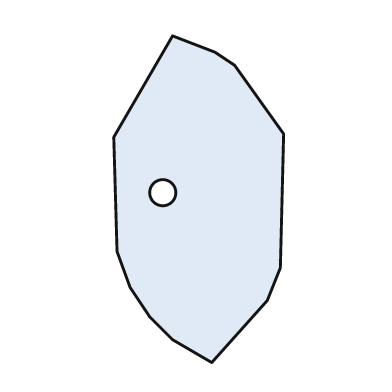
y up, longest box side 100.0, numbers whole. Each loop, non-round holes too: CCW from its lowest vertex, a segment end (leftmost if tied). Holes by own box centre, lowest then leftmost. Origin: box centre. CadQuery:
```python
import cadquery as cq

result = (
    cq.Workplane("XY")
    .moveTo(4.0, -50.0)
    .lineTo(21.0, -31.0)
    .lineTo(25.0, -21.0)
    .lineTo(26.0, 20.0)
    .lineTo(11.0, 41.0)
    .lineTo(5.0, 45.0)
    .lineTo(-8.0, 50.0)
    .lineTo(-26.0, 19.0)
    .lineTo(-25.0, -16.0)
    .lineTo(-21.0, -27.0)
    .lineTo(-15.0, -36.0)
    .lineTo(-8.0, -43.0)
    .close()
    .moveTo(-11.0, 2.0)
    .circle(4.0)
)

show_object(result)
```